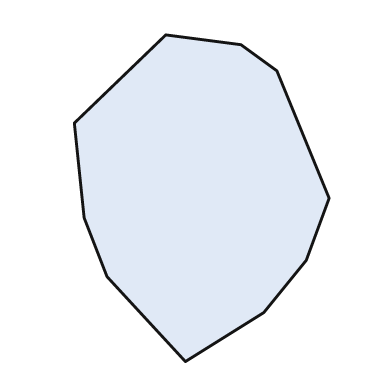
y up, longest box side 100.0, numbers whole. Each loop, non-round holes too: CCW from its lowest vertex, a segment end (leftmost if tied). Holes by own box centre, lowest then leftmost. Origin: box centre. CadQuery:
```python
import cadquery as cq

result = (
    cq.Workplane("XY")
    .moveTo(-5.0, -50.0)
    .lineTo(19.0, -35.0)
    .lineTo(32.0, -19.0)
    .lineTo(39.0, 0.0)
    .lineTo(23.0, 39.0)
    .lineTo(12.0, 47.0)
    .lineTo(-11.0, 50.0)
    .lineTo(-39.0, 23.0)
    .lineTo(-36.0, -6.0)
    .lineTo(-29.0, -24.0)
    .close()
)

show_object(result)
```